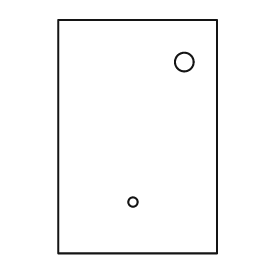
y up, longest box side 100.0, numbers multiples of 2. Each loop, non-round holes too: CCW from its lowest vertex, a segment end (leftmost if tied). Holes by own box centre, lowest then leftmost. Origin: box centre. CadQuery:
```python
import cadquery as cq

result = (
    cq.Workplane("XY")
    .moveTo(-34.0, -50.0)
    .lineTo(34.0, -50.0)
    .lineTo(34.0, 50.0)
    .lineTo(-34.0, 50.0)
    .close()
    .moveTo(-2.0, -28.0)
    .circle(2.0)
    .moveTo(20.0, 32.0)
    .circle(4.0)
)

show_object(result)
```